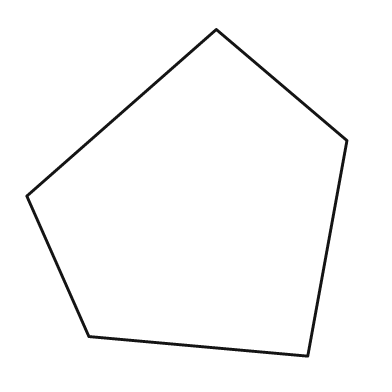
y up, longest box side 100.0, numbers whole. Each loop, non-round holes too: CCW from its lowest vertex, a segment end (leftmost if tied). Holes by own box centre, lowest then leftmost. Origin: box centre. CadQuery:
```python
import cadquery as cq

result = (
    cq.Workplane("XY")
    .moveTo(37.0, -50.0)
    .lineTo(49.0, 16.0)
    .lineTo(9.0, 50.0)
    .lineTo(-49.0, -1.0)
    .lineTo(-30.0, -44.0)
    .close()
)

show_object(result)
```